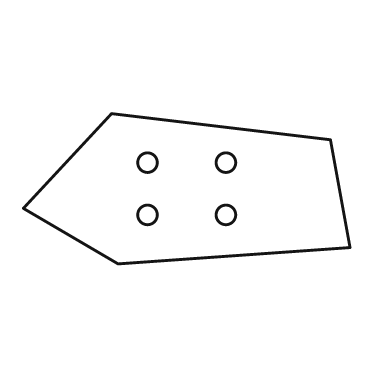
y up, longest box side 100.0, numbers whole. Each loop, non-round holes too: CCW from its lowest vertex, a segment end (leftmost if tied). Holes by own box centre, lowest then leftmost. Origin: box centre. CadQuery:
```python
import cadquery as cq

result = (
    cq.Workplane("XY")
    .moveTo(-21.0, -23.0)
    .lineTo(50.0, -18.0)
    .lineTo(44.0, 15.0)
    .lineTo(-23.0, 23.0)
    .lineTo(-50.0, -6.0)
    .close()
    .moveTo(-12.0, -8.0)
    .circle(3.0)
    .moveTo(12.0, -8.0)
    .circle(3.0)
    .moveTo(-12.0, 8.0)
    .circle(3.0)
    .moveTo(12.0, 8.0)
    .circle(3.0)
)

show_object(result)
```